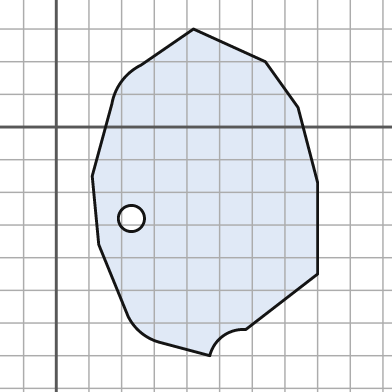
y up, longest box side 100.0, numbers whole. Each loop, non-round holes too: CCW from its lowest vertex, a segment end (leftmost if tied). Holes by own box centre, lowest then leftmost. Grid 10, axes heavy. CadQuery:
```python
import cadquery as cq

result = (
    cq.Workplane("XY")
    .moveTo(47.0, -70.0)
    .threePointArc((51.0, -64.0), (58.0, -62.0))
    .lineTo(80.0, -45.0)
    .lineTo(80.0, -17.0)
    .lineTo(74.0, 6.0)
    .lineTo(64.0, 20.0)
    .lineTo(42.0, 30.0)
    .lineTo(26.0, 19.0)
    .threePointArc((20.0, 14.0), (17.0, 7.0))
    .lineTo(11.0, -15.0)
    .lineTo(13.0, -36.0)
    .lineTo(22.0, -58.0)
    .threePointArc((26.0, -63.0), (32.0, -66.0))
    .close()
    .moveTo(23.0, -28.0)
    .circle(4.0)
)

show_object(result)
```